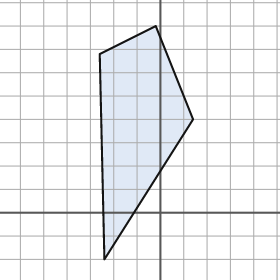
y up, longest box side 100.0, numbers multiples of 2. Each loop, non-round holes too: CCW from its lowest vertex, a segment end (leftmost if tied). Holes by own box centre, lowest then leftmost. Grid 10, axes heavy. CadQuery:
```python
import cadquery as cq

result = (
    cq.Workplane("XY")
    .moveTo(-24.0, -20.0)
    .lineTo(14.0, 40.0)
    .lineTo(-2.0, 80.0)
    .lineTo(-26.0, 68.0)
    .close()
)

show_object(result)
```